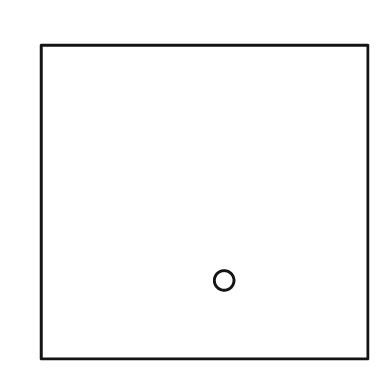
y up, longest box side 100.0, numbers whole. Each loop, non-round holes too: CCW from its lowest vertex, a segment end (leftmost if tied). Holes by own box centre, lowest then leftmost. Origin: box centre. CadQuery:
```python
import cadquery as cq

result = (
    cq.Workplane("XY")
    .moveTo(-50.0, -48.0)
    .lineTo(50.0, -48.0)
    .lineTo(50.0, 48.0)
    .lineTo(-50.0, 48.0)
    .close()
    .moveTo(6.0, -24.0)
    .circle(3.0)
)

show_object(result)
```